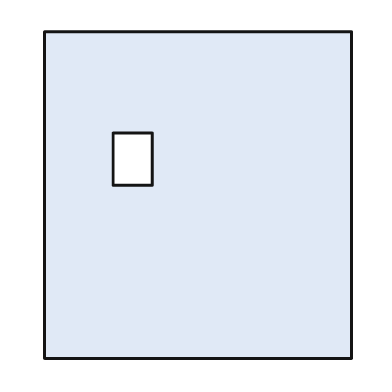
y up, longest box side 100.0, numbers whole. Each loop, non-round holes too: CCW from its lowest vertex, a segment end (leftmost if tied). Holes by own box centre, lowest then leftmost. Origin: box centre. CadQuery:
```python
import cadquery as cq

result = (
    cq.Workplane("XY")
    .moveTo(-47.0, -50.0)
    .lineTo(47.0, -50.0)
    .lineTo(47.0, 50.0)
    .lineTo(-47.0, 50.0)
    .close()
    .moveTo(-26.0, 3.0)
    .lineTo(-14.0, 3.0)
    .lineTo(-14.0, 19.0)
    .lineTo(-26.0, 19.0)
    .close()
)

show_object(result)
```